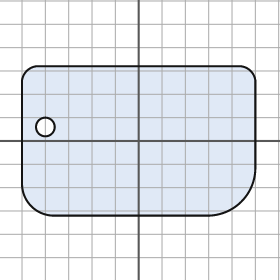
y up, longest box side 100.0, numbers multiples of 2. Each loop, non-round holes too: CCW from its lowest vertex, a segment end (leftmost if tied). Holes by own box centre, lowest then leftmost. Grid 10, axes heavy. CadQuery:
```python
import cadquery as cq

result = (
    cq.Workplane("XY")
    .moveTo(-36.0, -32.0)
    .lineTo(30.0, -32.0)
    .threePointArc((44.0, -26.0), (50.0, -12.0))
    .lineTo(50.0, 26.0)
    .threePointArc((48.0, 30.0), (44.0, 32.0))
    .lineTo(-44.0, 32.0)
    .threePointArc((-48.0, 30.0), (-50.0, 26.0))
    .lineTo(-50.0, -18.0)
    .threePointArc((-46.0, -28.0), (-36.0, -32.0))
    .close()
    .moveTo(-40.0, 6.0)
    .circle(4.0)
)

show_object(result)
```